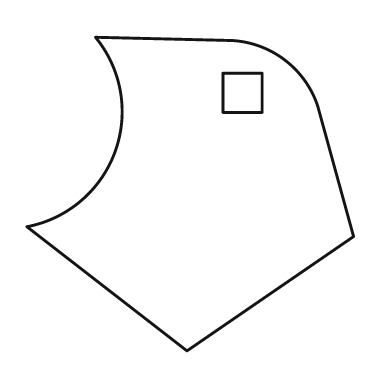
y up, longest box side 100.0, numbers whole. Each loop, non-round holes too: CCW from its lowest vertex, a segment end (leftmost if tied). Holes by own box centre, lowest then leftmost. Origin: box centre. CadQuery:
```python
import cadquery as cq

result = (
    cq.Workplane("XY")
    .moveTo(-1.0, -48.0)
    .lineTo(50.0, -13.0)
    .lineTo(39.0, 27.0)
    .threePointArc((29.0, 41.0), (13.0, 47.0))
    .lineTo(-29.0, 48.0)
    .threePointArc((-23.0, 13.0), (-50.0, -10.0))
    .close()
    .moveTo(10.0, 25.0)
    .lineTo(22.0, 25.0)
    .lineTo(22.0, 37.0)
    .lineTo(10.0, 37.0)
    .close()
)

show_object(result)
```